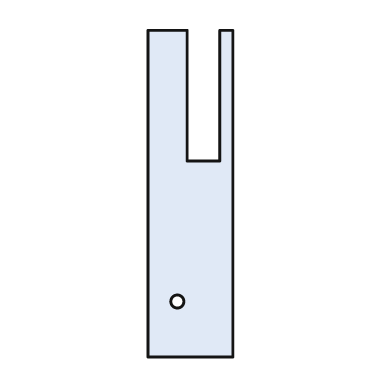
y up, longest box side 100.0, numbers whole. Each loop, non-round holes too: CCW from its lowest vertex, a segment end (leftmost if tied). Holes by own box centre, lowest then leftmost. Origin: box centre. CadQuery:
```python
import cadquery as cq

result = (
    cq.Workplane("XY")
    .moveTo(-13.0, -50.0)
    .lineTo(13.0, -50.0)
    .lineTo(13.0, 50.0)
    .lineTo(9.0, 50.0)
    .lineTo(9.0, 10.0)
    .lineTo(-1.0, 10.0)
    .lineTo(-1.0, 50.0)
    .lineTo(-13.0, 50.0)
    .close()
    .moveTo(-4.0, -33.0)
    .circle(2.0)
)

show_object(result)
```